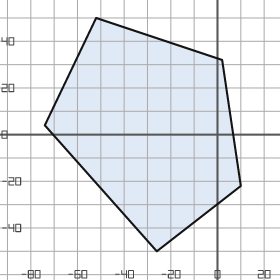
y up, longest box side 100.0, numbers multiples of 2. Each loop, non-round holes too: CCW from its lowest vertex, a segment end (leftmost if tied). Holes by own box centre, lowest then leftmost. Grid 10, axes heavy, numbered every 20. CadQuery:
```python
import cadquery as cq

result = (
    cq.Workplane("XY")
    .moveTo(-26.0, -50.0)
    .lineTo(10.0, -22.0)
    .lineTo(2.0, 32.0)
    .lineTo(-52.0, 50.0)
    .lineTo(-74.0, 4.0)
    .close()
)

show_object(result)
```